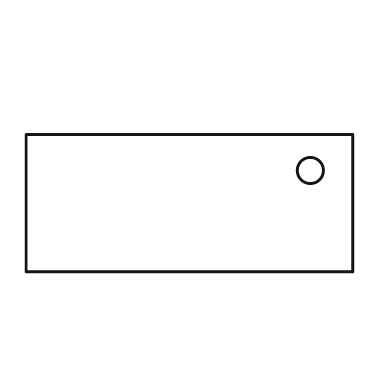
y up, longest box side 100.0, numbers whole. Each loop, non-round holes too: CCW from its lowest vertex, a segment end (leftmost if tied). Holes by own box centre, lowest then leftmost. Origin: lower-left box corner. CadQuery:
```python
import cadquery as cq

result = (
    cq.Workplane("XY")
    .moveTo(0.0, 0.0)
    .lineTo(100.0, 0.0)
    .lineTo(100.0, 42.0)
    .lineTo(0.0, 42.0)
    .close()
    .moveTo(87.0, 31.0)
    .circle(4.0)
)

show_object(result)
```